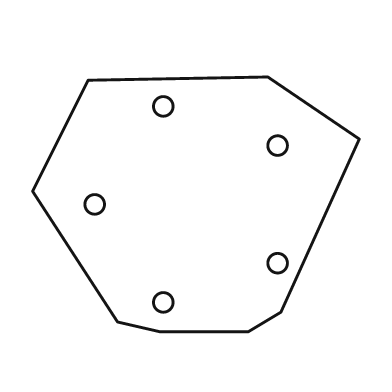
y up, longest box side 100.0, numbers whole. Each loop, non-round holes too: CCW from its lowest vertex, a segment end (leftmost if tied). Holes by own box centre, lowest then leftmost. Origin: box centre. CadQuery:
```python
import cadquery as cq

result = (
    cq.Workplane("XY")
    .moveTo(-11.0, -39.0)
    .lineTo(16.0, -39.0)
    .lineTo(26.0, -33.0)
    .lineTo(50.0, 20.0)
    .lineTo(22.0, 39.0)
    .lineTo(-33.0, 38.0)
    .lineTo(-50.0, 4.0)
    .lineTo(-24.0, -36.0)
    .close()
    .moveTo(-10.0, -30.0)
    .circle(3.0)
    .moveTo(25.0, -18.0)
    .circle(3.0)
    .moveTo(-31.0, 0.0)
    .circle(3.0)
    .moveTo(25.0, 18.0)
    .circle(3.0)
    .moveTo(-10.0, 30.0)
    .circle(3.0)
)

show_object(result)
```